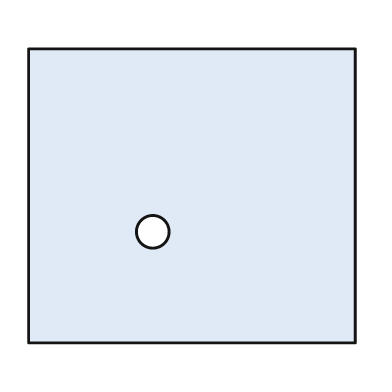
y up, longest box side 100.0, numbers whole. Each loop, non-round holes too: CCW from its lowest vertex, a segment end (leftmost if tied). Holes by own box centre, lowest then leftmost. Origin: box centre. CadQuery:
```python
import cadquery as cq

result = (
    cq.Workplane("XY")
    .moveTo(-50.0, -45.0)
    .lineTo(50.0, -45.0)
    .lineTo(50.0, 45.0)
    .lineTo(-50.0, 45.0)
    .close()
    .moveTo(-12.0, -11.0)
    .circle(5.0)
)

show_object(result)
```